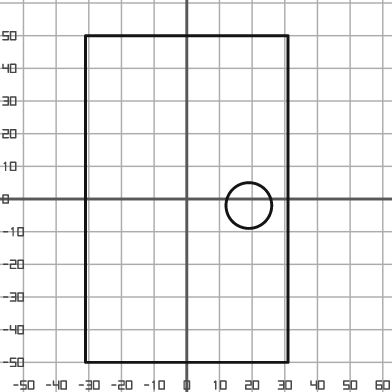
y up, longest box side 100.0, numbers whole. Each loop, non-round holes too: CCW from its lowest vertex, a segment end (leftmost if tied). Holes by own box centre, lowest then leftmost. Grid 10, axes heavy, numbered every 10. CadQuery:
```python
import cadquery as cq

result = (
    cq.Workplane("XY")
    .moveTo(-31.0, -50.0)
    .lineTo(31.0, -50.0)
    .lineTo(31.0, 50.0)
    .lineTo(-31.0, 50.0)
    .close()
    .moveTo(19.0, -2.0)
    .circle(7.0)
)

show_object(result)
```